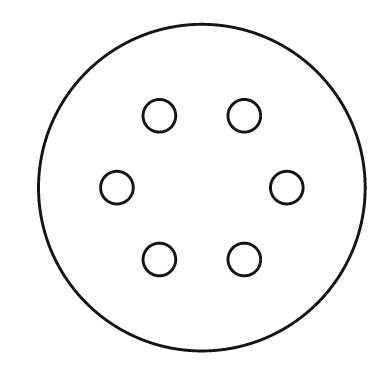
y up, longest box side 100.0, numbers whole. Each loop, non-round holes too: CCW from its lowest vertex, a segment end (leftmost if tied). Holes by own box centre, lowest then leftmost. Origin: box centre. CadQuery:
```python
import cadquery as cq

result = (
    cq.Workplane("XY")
    .moveTo(0.0, 0.0)
    .circle(50.0)
    .moveTo(-13.0, -22.0)
    .circle(5.0)
    .moveTo(13.0, -22.0)
    .circle(5.0)
    .moveTo(-26.0, 0.0)
    .circle(5.0)
    .moveTo(26.0, 0.0)
    .circle(5.0)
    .moveTo(-13.0, 22.0)
    .circle(5.0)
    .moveTo(13.0, 22.0)
    .circle(5.0)
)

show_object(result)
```